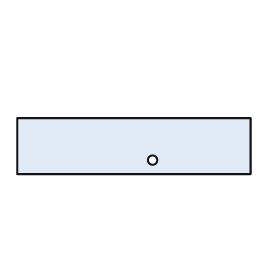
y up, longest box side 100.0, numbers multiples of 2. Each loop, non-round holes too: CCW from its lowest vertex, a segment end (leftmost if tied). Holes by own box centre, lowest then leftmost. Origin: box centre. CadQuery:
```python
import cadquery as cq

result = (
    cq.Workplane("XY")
    .moveTo(-50.0, -12.0)
    .lineTo(50.0, -12.0)
    .lineTo(50.0, 12.0)
    .lineTo(-50.0, 12.0)
    .close()
    .moveTo(8.0, -6.0)
    .circle(2.0)
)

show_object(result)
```